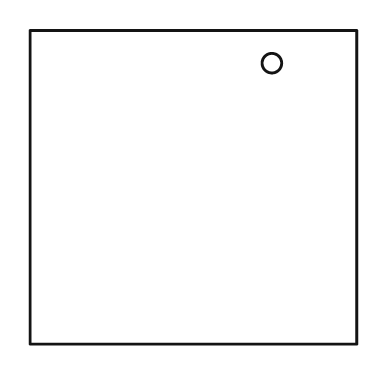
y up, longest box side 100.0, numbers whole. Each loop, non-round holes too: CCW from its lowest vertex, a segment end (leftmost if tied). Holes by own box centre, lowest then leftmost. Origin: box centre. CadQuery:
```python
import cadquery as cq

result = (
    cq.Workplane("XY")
    .moveTo(-50.0, -48.0)
    .lineTo(50.0, -48.0)
    .lineTo(50.0, 48.0)
    .lineTo(-50.0, 48.0)
    .close()
    .moveTo(24.0, 38.0)
    .circle(3.0)
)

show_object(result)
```